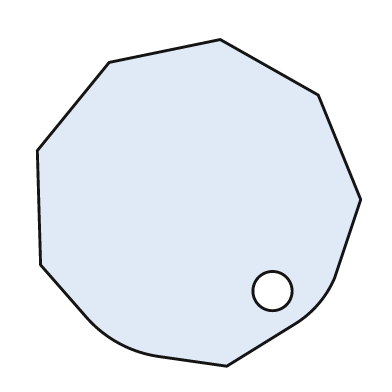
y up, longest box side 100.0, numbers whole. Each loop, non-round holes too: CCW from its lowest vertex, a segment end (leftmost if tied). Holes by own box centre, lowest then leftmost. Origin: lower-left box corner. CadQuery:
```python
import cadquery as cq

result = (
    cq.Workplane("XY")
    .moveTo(58.0, 0.0)
    .lineTo(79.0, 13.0)
    .threePointArc((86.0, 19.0), (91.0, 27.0))
    .lineTo(99.0, 51.0)
    .lineTo(86.0, 83.0)
    .lineTo(56.0, 100.0)
    .lineTo(22.0, 93.0)
    .lineTo(0.0, 66.0)
    .lineTo(1.0, 31.0)
    .lineTo(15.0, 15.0)
    .threePointArc((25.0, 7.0), (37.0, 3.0))
    .close()
    .moveTo(72.0, 23.0)
    .circle(6.0)
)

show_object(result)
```